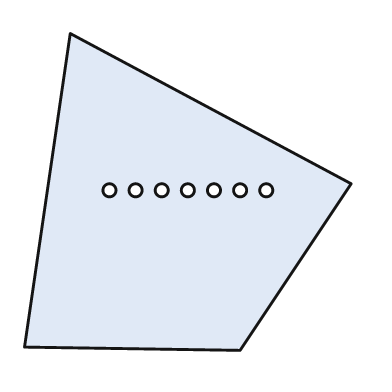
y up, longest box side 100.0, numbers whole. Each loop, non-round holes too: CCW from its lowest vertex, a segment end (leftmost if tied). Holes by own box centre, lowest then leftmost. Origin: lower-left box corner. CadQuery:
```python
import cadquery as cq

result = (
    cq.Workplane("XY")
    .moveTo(66.0, 0.0)
    .lineTo(100.0, 51.0)
    .lineTo(14.0, 97.0)
    .lineTo(0.0, 1.0)
    .close()
    .moveTo(26.0, 49.0)
    .circle(2.0)
    .moveTo(34.0, 49.0)
    .circle(2.0)
    .moveTo(42.0, 49.0)
    .circle(2.0)
    .moveTo(50.0, 49.0)
    .circle(2.0)
    .moveTo(58.0, 49.0)
    .circle(2.0)
    .moveTo(66.0, 49.0)
    .circle(2.0)
    .moveTo(74.0, 49.0)
    .circle(2.0)
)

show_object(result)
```